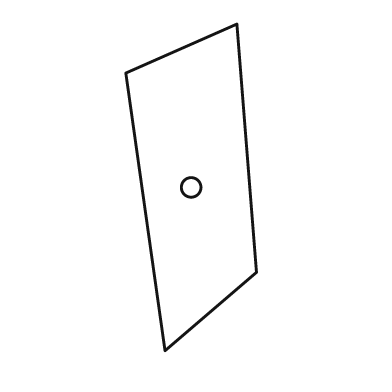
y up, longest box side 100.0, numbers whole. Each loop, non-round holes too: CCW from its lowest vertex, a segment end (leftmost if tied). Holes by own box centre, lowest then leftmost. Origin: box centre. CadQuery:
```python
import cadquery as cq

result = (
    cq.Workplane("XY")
    .moveTo(-8.0, -50.0)
    .lineTo(20.0, -26.0)
    .lineTo(14.0, 50.0)
    .lineTo(-20.0, 35.0)
    .close()
    .moveTo(0.0, 0.0)
    .circle(3.0)
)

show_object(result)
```